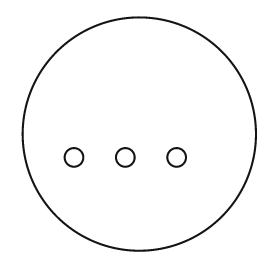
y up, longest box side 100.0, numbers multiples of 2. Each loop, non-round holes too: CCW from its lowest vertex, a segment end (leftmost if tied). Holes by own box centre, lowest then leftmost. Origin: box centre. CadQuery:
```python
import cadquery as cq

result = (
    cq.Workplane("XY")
    .moveTo(0.0, 0.0)
    .circle(50.0)
    .moveTo(-28.0, -10.0)
    .circle(4.0)
    .moveTo(-6.0, -10.0)
    .circle(4.0)
    .moveTo(16.0, -10.0)
    .circle(4.0)
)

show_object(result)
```